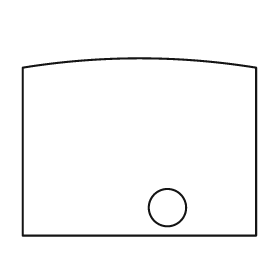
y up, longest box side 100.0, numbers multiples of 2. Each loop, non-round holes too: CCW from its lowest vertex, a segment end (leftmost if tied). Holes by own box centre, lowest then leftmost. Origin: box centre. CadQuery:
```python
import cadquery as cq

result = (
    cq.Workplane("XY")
    .moveTo(-50.0, -38.0)
    .lineTo(50.0, -38.0)
    .lineTo(50.0, 34.0)
    .threePointArc((0.0, 38.0), (-50.0, 34.0))
    .close()
    .moveTo(12.0, -26.0)
    .circle(8.0)
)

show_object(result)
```